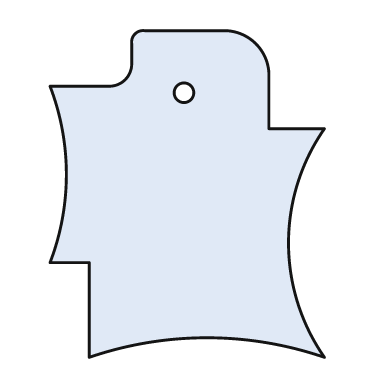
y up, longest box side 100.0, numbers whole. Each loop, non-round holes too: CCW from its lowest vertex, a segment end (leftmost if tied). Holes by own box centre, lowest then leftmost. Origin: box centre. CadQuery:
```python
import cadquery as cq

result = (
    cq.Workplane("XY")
    .moveTo(-30.0, -50.0)
    .threePointArc((6.0, -44.0), (42.0, -50.0))
    .threePointArc((31.0, -15.0), (42.0, 20.0))
    .lineTo(25.0, 20.0)
    .lineTo(25.0, 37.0)
    .threePointArc((21.0, 46.0), (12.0, 50.0))
    .lineTo(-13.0, 50.0)
    .threePointArc((-16.0, 49.0), (-17.0, 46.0))
    .lineTo(-17.0, 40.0)
    .threePointArc((-19.0, 35.0), (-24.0, 33.0))
    .lineTo(-42.0, 33.0)
    .threePointArc((-37.0, 6.0), (-42.0, -21.0))
    .lineTo(-30.0, -21.0)
    .close()
    .moveTo(-1.0, 31.0)
    .circle(3.0)
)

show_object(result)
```